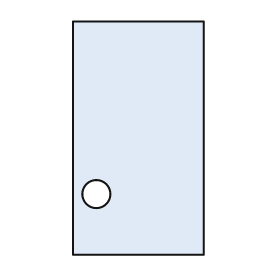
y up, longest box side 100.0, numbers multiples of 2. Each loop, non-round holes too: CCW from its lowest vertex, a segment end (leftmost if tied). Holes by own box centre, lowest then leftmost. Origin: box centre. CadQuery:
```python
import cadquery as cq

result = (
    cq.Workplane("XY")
    .moveTo(-28.0, -50.0)
    .lineTo(28.0, -50.0)
    .lineTo(28.0, 50.0)
    .lineTo(-28.0, 50.0)
    .close()
    .moveTo(-18.0, -24.0)
    .circle(6.0)
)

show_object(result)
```